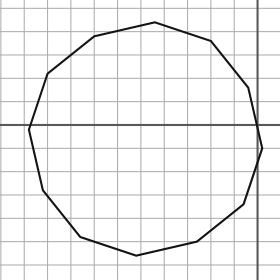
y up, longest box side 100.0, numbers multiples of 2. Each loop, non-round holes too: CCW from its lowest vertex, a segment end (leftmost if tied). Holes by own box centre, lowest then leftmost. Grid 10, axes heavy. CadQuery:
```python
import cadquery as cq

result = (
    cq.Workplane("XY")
    .moveTo(-52.0, -56.0)
    .lineTo(-26.0, -50.0)
    .lineTo(-6.0, -34.0)
    .lineTo(2.0, -10.0)
    .lineTo(-4.0, 16.0)
    .lineTo(-20.0, 36.0)
    .lineTo(-44.0, 44.0)
    .lineTo(-70.0, 38.0)
    .lineTo(-90.0, 22.0)
    .lineTo(-98.0, -2.0)
    .lineTo(-92.0, -28.0)
    .lineTo(-76.0, -48.0)
    .close()
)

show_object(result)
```